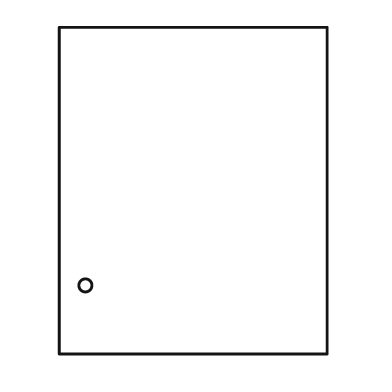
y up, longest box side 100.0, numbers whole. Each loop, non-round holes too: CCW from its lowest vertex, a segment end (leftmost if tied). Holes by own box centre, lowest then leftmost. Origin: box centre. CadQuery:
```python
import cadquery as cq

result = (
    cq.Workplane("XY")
    .moveTo(-41.0, -50.0)
    .lineTo(41.0, -50.0)
    .lineTo(41.0, 50.0)
    .lineTo(-41.0, 50.0)
    .close()
    .moveTo(-33.0, -29.0)
    .circle(2.0)
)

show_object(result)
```